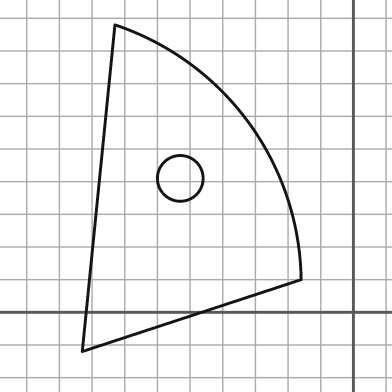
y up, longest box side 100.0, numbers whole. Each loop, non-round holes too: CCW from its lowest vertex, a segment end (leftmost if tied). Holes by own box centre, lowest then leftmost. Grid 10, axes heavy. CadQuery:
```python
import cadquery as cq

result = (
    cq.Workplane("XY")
    .moveTo(-83.0, -12.0)
    .lineTo(-16.0, 10.0)
    .threePointArc((-32.0, 58.0), (-73.0, 88.0))
    .close()
    .moveTo(-53.0, 41.0)
    .circle(7.0)
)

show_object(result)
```